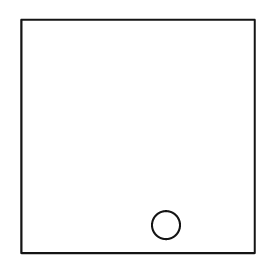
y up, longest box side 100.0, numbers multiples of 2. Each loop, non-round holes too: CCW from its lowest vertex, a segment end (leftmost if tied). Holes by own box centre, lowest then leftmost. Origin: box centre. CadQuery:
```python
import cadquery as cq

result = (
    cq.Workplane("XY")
    .moveTo(-50.0, -50.0)
    .lineTo(50.0, -50.0)
    .lineTo(50.0, 50.0)
    .lineTo(-50.0, 50.0)
    .close()
    .moveTo(12.0, -38.0)
    .circle(6.0)
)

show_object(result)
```